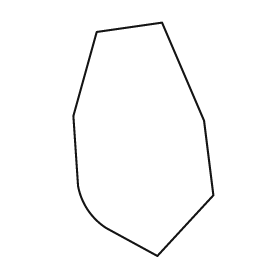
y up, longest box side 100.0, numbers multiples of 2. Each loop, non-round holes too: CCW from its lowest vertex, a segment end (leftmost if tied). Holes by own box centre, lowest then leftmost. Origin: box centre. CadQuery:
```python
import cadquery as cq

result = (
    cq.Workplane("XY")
    .moveTo(6.0, -50.0)
    .lineTo(30.0, -24.0)
    .lineTo(26.0, 8.0)
    .lineTo(8.0, 50.0)
    .lineTo(-20.0, 46.0)
    .lineTo(-30.0, 10.0)
    .lineTo(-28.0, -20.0)
    .threePointArc((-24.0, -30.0), (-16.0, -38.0))
    .close()
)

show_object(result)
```